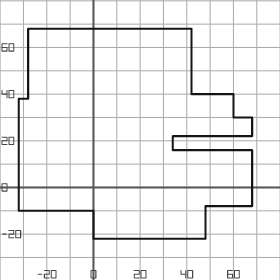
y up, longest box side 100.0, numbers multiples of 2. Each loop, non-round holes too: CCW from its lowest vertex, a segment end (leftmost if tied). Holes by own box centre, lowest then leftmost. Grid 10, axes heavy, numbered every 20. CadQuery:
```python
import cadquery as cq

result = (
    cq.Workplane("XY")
    .moveTo(0.0, -22.0)
    .lineTo(48.0, -22.0)
    .lineTo(48.0, -8.0)
    .lineTo(68.0, -8.0)
    .lineTo(68.0, 16.0)
    .lineTo(34.0, 16.0)
    .lineTo(34.0, 22.0)
    .lineTo(68.0, 22.0)
    .lineTo(68.0, 30.0)
    .lineTo(60.0, 30.0)
    .lineTo(60.0, 40.0)
    .lineTo(42.0, 40.0)
    .lineTo(42.0, 68.0)
    .lineTo(-28.0, 68.0)
    .lineTo(-28.0, 38.0)
    .lineTo(-32.0, 38.0)
    .lineTo(-32.0, -10.0)
    .lineTo(0.0, -10.0)
    .close()
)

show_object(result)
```